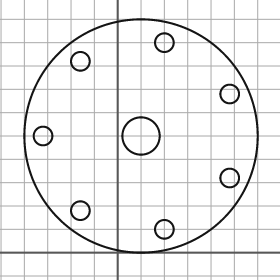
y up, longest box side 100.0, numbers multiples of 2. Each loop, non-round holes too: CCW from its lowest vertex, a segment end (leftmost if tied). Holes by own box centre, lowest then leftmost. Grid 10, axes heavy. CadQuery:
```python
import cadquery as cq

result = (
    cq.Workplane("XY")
    .moveTo(10.0, 50.0)
    .circle(50.0)
    .moveTo(20.0, 10.0)
    .circle(4.0)
    .moveTo(-16.0, 18.0)
    .circle(4.0)
    .moveTo(48.0, 32.0)
    .circle(4.0)
    .moveTo(-32.0, 50.0)
    .circle(4.0)
    .moveTo(10.0, 50.0)
    .circle(8.0)
    .moveTo(48.0, 68.0)
    .circle(4.0)
    .moveTo(-16.0, 82.0)
    .circle(4.0)
    .moveTo(20.0, 90.0)
    .circle(4.0)
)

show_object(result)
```